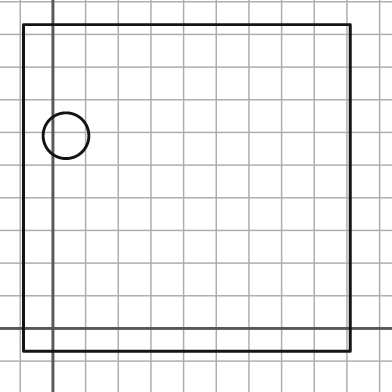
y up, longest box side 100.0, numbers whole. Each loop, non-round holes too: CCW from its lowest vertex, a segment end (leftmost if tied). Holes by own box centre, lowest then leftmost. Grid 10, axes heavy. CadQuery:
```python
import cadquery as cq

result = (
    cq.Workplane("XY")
    .moveTo(-9.0, -7.0)
    .lineTo(91.0, -7.0)
    .lineTo(91.0, 93.0)
    .lineTo(-9.0, 93.0)
    .close()
    .moveTo(4.0, 59.0)
    .circle(7.0)
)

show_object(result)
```